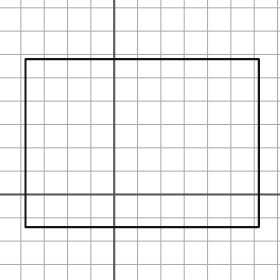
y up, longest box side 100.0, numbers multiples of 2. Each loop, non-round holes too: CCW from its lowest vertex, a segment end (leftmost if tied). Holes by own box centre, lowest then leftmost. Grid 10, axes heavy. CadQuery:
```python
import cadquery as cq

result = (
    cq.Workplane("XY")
    .moveTo(-38.0, -14.0)
    .lineTo(62.0, -14.0)
    .lineTo(62.0, 58.0)
    .lineTo(-38.0, 58.0)
    .close()
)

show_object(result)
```